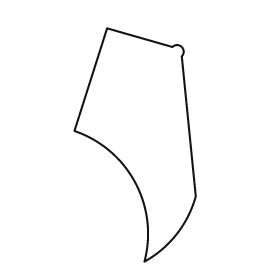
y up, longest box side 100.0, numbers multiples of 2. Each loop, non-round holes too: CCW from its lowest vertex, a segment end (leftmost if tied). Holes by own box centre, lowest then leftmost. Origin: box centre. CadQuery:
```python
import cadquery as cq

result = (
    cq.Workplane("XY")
    .moveTo(4.0, -50.0)
    .threePointArc((18.0, -38.0), (26.0, -22.0))
    .lineTo(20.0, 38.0)
    .threePointArc((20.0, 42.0), (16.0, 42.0))
    .lineTo(-12.0, 50.0)
    .lineTo(-26.0, 6.0)
    .threePointArc((0.0, -16.0), (4.0, -50.0))
    .close()
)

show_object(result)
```